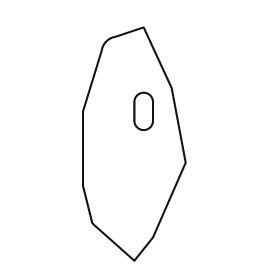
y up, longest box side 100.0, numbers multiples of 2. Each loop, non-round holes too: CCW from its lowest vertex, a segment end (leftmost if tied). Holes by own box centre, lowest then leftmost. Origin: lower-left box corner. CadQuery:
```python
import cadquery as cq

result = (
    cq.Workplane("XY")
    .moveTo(22.0, 0.0)
    .lineTo(30.0, 10.0)
    .lineTo(44.0, 42.0)
    .lineTo(38.0, 74.0)
    .lineTo(26.0, 100.0)
    .lineTo(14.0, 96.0)
    .threePointArc((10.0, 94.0), (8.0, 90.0))
    .lineTo(0.0, 64.0)
    .lineTo(0.0, 32.0)
    .lineTo(4.0, 16.0)
    .close()
    .moveTo(22.0, 60.0)
    .threePointArc((26.0, 56.0), (30.0, 60.0))
    .lineTo(30.0, 68.0)
    .threePointArc((26.0, 72.0), (22.0, 68.0))
    .close()
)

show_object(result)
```